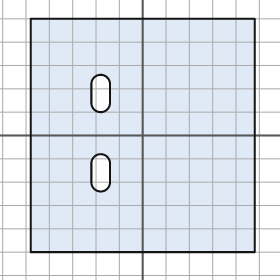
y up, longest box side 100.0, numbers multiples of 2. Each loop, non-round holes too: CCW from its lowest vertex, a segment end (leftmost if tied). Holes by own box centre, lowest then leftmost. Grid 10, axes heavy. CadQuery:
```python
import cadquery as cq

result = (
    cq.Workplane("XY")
    .moveTo(-48.0, -50.0)
    .lineTo(48.0, -50.0)
    .lineTo(48.0, 50.0)
    .lineTo(-48.0, 50.0)
    .close()
    .moveTo(-22.0, -20.0)
    .threePointArc((-18.0, -24.0), (-14.0, -20.0))
    .lineTo(-14.0, -12.0)
    .threePointArc((-18.0, -8.0), (-22.0, -12.0))
    .close()
    .moveTo(-22.0, 14.0)
    .threePointArc((-18.0, 10.0), (-14.0, 14.0))
    .lineTo(-14.0, 22.0)
    .threePointArc((-18.0, 26.0), (-22.0, 22.0))
    .close()
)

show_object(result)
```